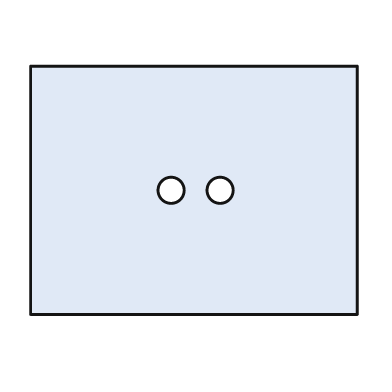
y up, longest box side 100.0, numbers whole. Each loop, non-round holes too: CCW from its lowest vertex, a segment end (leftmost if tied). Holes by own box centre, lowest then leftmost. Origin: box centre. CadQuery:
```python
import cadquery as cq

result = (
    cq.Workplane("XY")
    .moveTo(-50.0, -38.0)
    .lineTo(50.0, -38.0)
    .lineTo(50.0, 38.0)
    .lineTo(-50.0, 38.0)
    .close()
    .moveTo(-7.0, 0.0)
    .circle(4.0)
    .moveTo(8.0, 0.0)
    .circle(4.0)
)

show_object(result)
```